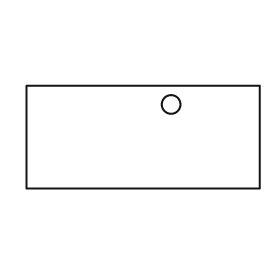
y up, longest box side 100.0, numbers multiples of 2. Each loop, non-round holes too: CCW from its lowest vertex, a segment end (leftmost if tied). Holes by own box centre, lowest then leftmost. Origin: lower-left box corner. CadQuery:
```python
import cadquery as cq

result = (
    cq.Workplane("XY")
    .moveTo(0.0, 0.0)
    .lineTo(100.0, 0.0)
    .lineTo(100.0, 44.0)
    .lineTo(0.0, 44.0)
    .close()
    .moveTo(62.0, 36.0)
    .circle(4.0)
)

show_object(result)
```